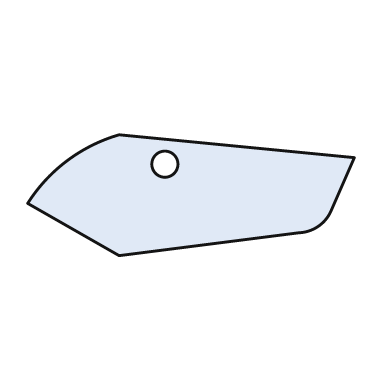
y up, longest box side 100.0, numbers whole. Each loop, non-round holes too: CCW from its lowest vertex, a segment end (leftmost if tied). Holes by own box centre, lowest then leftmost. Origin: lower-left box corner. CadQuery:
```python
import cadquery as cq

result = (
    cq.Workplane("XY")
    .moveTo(28.0, 0.0)
    .lineTo(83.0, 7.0)
    .threePointArc((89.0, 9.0), (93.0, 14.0))
    .lineTo(100.0, 30.0)
    .lineTo(28.0, 37.0)
    .threePointArc((12.0, 29.0), (0.0, 16.0))
    .close()
    .moveTo(42.0, 28.0)
    .circle(4.0)
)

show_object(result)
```